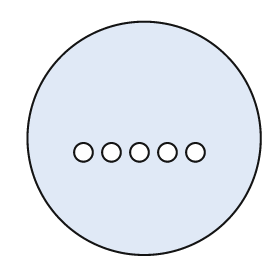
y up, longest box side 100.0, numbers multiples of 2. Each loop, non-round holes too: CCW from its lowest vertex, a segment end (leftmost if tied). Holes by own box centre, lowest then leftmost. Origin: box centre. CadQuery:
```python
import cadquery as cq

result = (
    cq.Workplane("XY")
    .moveTo(0.0, 0.0)
    .circle(50.0)
    .moveTo(-26.0, -6.0)
    .circle(4.0)
    .moveTo(-14.0, -6.0)
    .circle(4.0)
    .moveTo(-2.0, -6.0)
    .circle(4.0)
    .moveTo(10.0, -6.0)
    .circle(4.0)
    .moveTo(22.0, -6.0)
    .circle(4.0)
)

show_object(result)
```